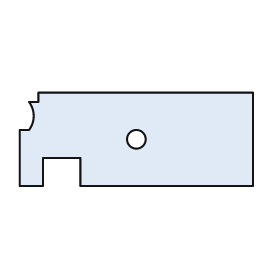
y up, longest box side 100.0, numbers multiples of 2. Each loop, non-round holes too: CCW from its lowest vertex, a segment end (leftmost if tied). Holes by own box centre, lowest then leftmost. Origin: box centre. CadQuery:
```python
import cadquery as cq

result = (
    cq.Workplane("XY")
    .moveTo(-50.0, -20.0)
    .lineTo(-40.0, -20.0)
    .lineTo(-40.0, -8.0)
    .lineTo(-24.0, -8.0)
    .lineTo(-24.0, -20.0)
    .lineTo(50.0, -20.0)
    .lineTo(50.0, 20.0)
    .lineTo(-42.0, 20.0)
    .lineTo(-42.0, 16.0)
    .lineTo(-46.0, 16.0)
    .threePointArc((-44.0, 10.0), (-46.0, 4.0))
    .lineTo(-50.0, 4.0)
    .close()
    .moveTo(0.0, 0.0)
    .circle(4.0)
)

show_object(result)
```